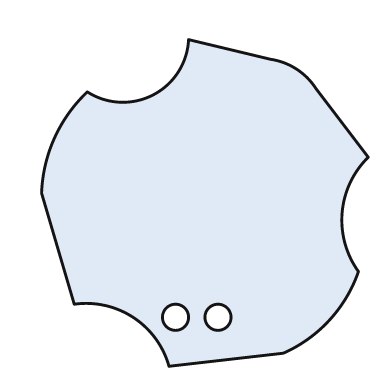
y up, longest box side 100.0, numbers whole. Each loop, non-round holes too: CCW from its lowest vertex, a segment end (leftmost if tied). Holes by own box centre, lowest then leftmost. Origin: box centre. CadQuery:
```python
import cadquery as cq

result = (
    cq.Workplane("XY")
    .moveTo(-11.0, -50.0)
    .lineTo(24.0, -46.0)
    .threePointArc((38.0, -36.0), (47.0, -21.0))
    .threePointArc((42.0, -3.0), (50.0, 14.0))
    .lineTo(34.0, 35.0)
    .threePointArc((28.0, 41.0), (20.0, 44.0))
    .lineTo(-5.0, 50.0)
    .threePointArc((-16.0, 33.0), (-36.0, 34.0))
    .threePointArc((-46.0, 20.0), (-50.0, 3.0))
    .lineTo(-40.0, -31.0)
    .threePointArc((-22.0, -35.0), (-11.0, -50.0))
    .close()
    .moveTo(-9.0, -35.0)
    .circle(4.0)
    .moveTo(4.0, -35.0)
    .circle(4.0)
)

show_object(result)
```